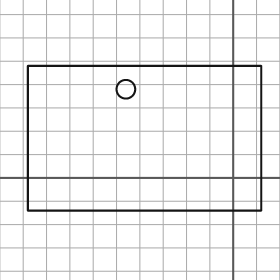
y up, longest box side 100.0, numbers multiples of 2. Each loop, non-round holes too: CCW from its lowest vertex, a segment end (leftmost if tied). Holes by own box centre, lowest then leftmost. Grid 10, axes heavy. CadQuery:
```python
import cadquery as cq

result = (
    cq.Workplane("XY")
    .moveTo(-88.0, -14.0)
    .lineTo(12.0, -14.0)
    .lineTo(12.0, 48.0)
    .lineTo(-88.0, 48.0)
    .close()
    .moveTo(-46.0, 38.0)
    .circle(4.0)
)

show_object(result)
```